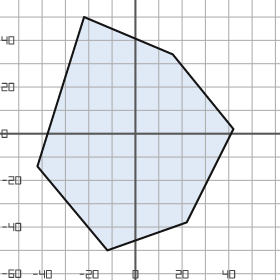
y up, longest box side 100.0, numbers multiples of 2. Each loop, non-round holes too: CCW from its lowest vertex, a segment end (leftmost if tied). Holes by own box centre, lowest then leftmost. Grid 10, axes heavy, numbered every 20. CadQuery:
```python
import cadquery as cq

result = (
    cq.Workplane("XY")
    .moveTo(-12.0, -50.0)
    .lineTo(22.0, -38.0)
    .lineTo(42.0, 2.0)
    .lineTo(16.0, 34.0)
    .lineTo(-22.0, 50.0)
    .lineTo(-42.0, -14.0)
    .close()
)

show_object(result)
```